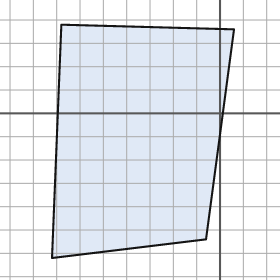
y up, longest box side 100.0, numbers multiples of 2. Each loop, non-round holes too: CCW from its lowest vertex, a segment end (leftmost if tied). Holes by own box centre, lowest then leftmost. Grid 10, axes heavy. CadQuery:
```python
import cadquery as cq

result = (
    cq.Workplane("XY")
    .moveTo(-72.0, -62.0)
    .lineTo(-6.0, -54.0)
    .lineTo(6.0, 36.0)
    .lineTo(-68.0, 38.0)
    .close()
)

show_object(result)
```